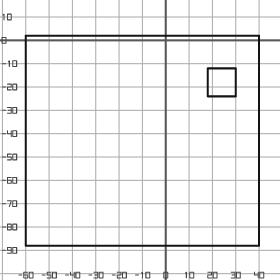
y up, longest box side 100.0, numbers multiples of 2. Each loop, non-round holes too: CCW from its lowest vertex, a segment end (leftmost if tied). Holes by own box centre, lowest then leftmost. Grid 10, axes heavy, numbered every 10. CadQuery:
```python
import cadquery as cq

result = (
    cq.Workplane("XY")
    .moveTo(-60.0, -88.0)
    .lineTo(40.0, -88.0)
    .lineTo(40.0, 2.0)
    .lineTo(-60.0, 2.0)
    .close()
    .moveTo(18.0, -24.0)
    .lineTo(30.0, -24.0)
    .lineTo(30.0, -12.0)
    .lineTo(18.0, -12.0)
    .close()
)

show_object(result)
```